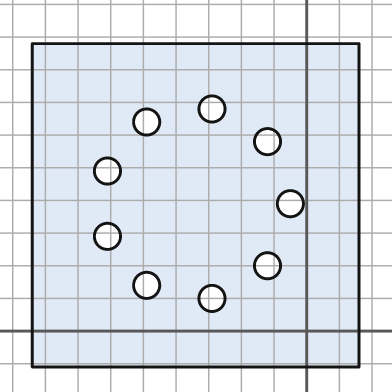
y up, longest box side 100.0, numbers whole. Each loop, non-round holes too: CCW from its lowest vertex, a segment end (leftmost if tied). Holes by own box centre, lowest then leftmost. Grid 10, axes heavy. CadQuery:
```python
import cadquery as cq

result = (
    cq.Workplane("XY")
    .moveTo(-84.0, -11.0)
    .lineTo(16.0, -11.0)
    .lineTo(16.0, 88.0)
    .lineTo(-84.0, 88.0)
    .close()
    .moveTo(-29.0, 10.0)
    .circle(4.0)
    .moveTo(-49.0, 14.0)
    .circle(4.0)
    .moveTo(-12.0, 20.0)
    .circle(4.0)
    .moveTo(-61.0, 29.0)
    .circle(4.0)
    .moveTo(-5.0, 39.0)
    .circle(4.0)
    .moveTo(-61.0, 49.0)
    .circle(4.0)
    .moveTo(-12.0, 58.0)
    .circle(4.0)
    .moveTo(-49.0, 64.0)
    .circle(4.0)
    .moveTo(-29.0, 68.0)
    .circle(4.0)
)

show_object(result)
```